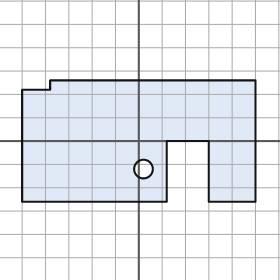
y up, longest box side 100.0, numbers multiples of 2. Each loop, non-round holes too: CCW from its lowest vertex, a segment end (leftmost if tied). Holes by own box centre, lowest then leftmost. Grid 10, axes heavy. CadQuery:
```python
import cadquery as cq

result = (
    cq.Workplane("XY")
    .moveTo(-50.0, -26.0)
    .lineTo(12.0, -26.0)
    .lineTo(12.0, 0.0)
    .lineTo(30.0, 0.0)
    .lineTo(30.0, -26.0)
    .lineTo(50.0, -26.0)
    .lineTo(50.0, 26.0)
    .lineTo(-38.0, 26.0)
    .lineTo(-38.0, 22.0)
    .lineTo(-50.0, 22.0)
    .close()
    .moveTo(2.0, -12.0)
    .circle(4.0)
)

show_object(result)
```